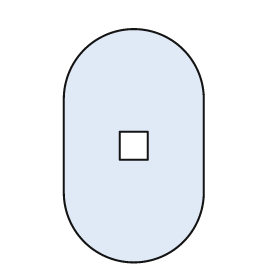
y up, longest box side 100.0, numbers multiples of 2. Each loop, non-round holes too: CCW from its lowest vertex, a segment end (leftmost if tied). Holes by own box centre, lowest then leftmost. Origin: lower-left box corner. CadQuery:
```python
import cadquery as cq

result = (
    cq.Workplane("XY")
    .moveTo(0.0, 30.0)
    .threePointArc((30.0, 0.0), (60.0, 30.0))
    .lineTo(60.0, 70.0)
    .threePointArc((30.0, 100.0), (0.0, 70.0))
    .close()
    .moveTo(24.0, 44.0)
    .lineTo(36.0, 44.0)
    .lineTo(36.0, 56.0)
    .lineTo(24.0, 56.0)
    .close()
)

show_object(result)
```